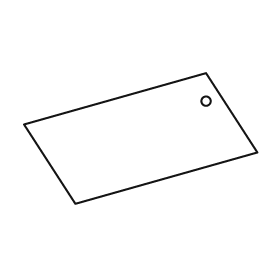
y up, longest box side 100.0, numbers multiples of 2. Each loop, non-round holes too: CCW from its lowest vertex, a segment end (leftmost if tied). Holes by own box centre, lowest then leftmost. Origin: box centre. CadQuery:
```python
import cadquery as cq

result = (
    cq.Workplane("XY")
    .moveTo(-28.0, -28.0)
    .lineTo(50.0, -6.0)
    .lineTo(28.0, 28.0)
    .lineTo(-50.0, 6.0)
    .close()
    .moveTo(28.0, 16.0)
    .circle(2.0)
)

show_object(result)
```